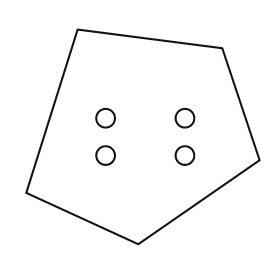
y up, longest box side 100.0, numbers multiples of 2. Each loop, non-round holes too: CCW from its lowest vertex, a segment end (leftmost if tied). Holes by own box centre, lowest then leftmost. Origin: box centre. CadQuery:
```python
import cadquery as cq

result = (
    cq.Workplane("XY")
    .moveTo(-2.0, -46.0)
    .lineTo(50.0, -10.0)
    .lineTo(34.0, 38.0)
    .lineTo(-28.0, 46.0)
    .lineTo(-50.0, -24.0)
    .close()
    .moveTo(-16.0, -8.0)
    .circle(4.0)
    .moveTo(18.0, -8.0)
    .circle(4.0)
    .moveTo(-16.0, 8.0)
    .circle(4.0)
    .moveTo(18.0, 8.0)
    .circle(4.0)
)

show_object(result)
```